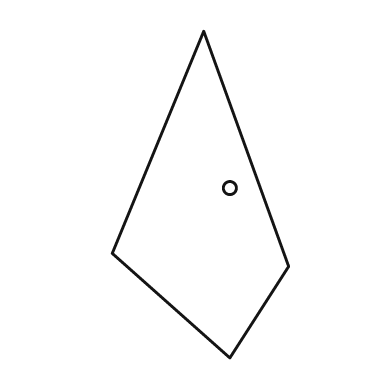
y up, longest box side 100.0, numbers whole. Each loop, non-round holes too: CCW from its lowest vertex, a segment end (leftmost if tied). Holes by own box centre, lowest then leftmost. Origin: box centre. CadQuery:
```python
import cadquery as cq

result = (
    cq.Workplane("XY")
    .moveTo(9.0, -50.0)
    .lineTo(27.0, -22.0)
    .lineTo(1.0, 50.0)
    .lineTo(-27.0, -18.0)
    .close()
    .moveTo(9.0, 2.0)
    .circle(2.0)
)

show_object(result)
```